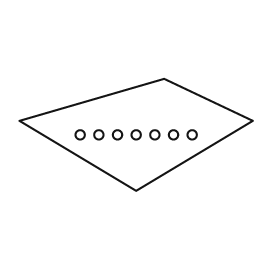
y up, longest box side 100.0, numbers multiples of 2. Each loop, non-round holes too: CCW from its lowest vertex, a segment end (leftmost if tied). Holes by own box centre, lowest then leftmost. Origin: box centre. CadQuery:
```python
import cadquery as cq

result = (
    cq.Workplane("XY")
    .moveTo(0.0, -24.0)
    .lineTo(50.0, 6.0)
    .lineTo(12.0, 24.0)
    .lineTo(-50.0, 6.0)
    .close()
    .moveTo(-24.0, 0.0)
    .circle(2.0)
    .moveTo(-16.0, 0.0)
    .circle(2.0)
    .moveTo(-8.0, 0.0)
    .circle(2.0)
    .moveTo(0.0, 0.0)
    .circle(2.0)
    .moveTo(8.0, 0.0)
    .circle(2.0)
    .moveTo(16.0, 0.0)
    .circle(2.0)
    .moveTo(24.0, 0.0)
    .circle(2.0)
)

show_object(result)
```